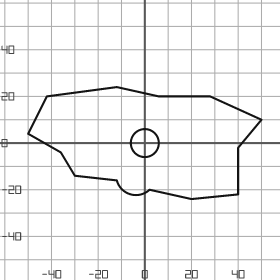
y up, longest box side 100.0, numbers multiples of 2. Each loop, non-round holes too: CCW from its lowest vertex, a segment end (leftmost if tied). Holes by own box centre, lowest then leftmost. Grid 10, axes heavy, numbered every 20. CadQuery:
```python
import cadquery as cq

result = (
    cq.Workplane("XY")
    .moveTo(20.0, -24.0)
    .lineTo(40.0, -22.0)
    .lineTo(40.0, -2.0)
    .lineTo(50.0, 10.0)
    .lineTo(28.0, 20.0)
    .lineTo(6.0, 20.0)
    .lineTo(-12.0, 24.0)
    .lineTo(-42.0, 20.0)
    .lineTo(-50.0, 4.0)
    .lineTo(-36.0, -4.0)
    .lineTo(-30.0, -14.0)
    .lineTo(-12.0, -16.0)
    .threePointArc((-6.0, -22.0), (2.0, -20.0))
    .close()
    .moveTo(0.0, 0.0)
    .circle(6.0)
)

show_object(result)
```